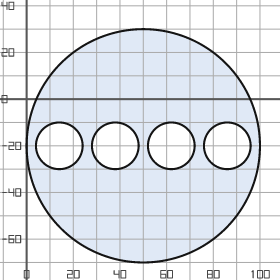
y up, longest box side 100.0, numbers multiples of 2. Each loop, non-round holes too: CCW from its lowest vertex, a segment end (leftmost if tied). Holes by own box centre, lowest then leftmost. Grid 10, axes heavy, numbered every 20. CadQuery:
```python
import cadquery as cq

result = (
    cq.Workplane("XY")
    .moveTo(50.0, -20.0)
    .circle(50.0)
    .moveTo(14.0, -20.0)
    .circle(10.0)
    .moveTo(38.0, -20.0)
    .circle(10.0)
    .moveTo(62.0, -20.0)
    .circle(10.0)
    .moveTo(86.0, -20.0)
    .circle(10.0)
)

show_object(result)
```